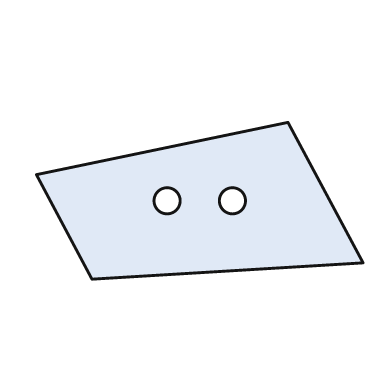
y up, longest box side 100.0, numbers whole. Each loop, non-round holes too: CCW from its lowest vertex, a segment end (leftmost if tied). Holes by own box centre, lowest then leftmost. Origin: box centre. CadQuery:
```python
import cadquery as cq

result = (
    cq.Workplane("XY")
    .moveTo(-33.0, -24.0)
    .lineTo(50.0, -19.0)
    .lineTo(27.0, 24.0)
    .lineTo(-50.0, 8.0)
    .close()
    .moveTo(-10.0, 0.0)
    .circle(4.0)
    .moveTo(10.0, 0.0)
    .circle(4.0)
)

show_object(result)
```